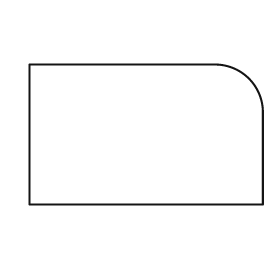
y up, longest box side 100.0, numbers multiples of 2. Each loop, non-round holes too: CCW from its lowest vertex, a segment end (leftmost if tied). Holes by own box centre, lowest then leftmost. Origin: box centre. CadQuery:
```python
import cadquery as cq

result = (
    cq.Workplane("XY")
    .moveTo(-50.0, -30.0)
    .lineTo(50.0, -30.0)
    .lineTo(50.0, 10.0)
    .threePointArc((44.0, 24.0), (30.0, 30.0))
    .lineTo(-50.0, 30.0)
    .close()
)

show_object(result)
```